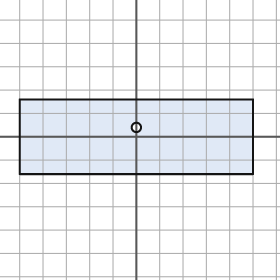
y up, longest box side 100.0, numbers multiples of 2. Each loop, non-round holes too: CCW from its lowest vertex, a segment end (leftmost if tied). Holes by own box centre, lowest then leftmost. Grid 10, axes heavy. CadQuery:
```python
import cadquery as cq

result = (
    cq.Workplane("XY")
    .moveTo(-50.0, -16.0)
    .lineTo(50.0, -16.0)
    .lineTo(50.0, 16.0)
    .lineTo(-50.0, 16.0)
    .close()
    .moveTo(0.0, 4.0)
    .circle(2.0)
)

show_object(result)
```